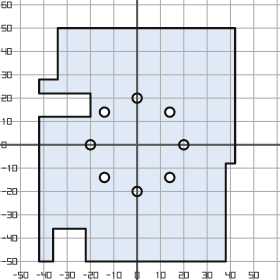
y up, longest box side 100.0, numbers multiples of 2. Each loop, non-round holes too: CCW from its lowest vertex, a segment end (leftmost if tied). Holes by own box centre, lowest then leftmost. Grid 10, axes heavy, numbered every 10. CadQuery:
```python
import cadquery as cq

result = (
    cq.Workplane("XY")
    .moveTo(-42.0, -50.0)
    .lineTo(-36.0, -50.0)
    .lineTo(-36.0, -36.0)
    .lineTo(-22.0, -36.0)
    .lineTo(-22.0, -50.0)
    .lineTo(38.0, -50.0)
    .lineTo(38.0, -8.0)
    .lineTo(42.0, -8.0)
    .lineTo(42.0, 50.0)
    .lineTo(-34.0, 50.0)
    .lineTo(-34.0, 28.0)
    .lineTo(-42.0, 28.0)
    .lineTo(-42.0, 22.0)
    .lineTo(-20.0, 22.0)
    .lineTo(-20.0, 12.0)
    .lineTo(-42.0, 12.0)
    .close()
    .moveTo(0.0, -20.0)
    .circle(2.0)
    .moveTo(-14.0, -14.0)
    .circle(2.0)
    .moveTo(14.0, -14.0)
    .circle(2.0)
    .moveTo(-20.0, 0.0)
    .circle(2.0)
    .moveTo(20.0, 0.0)
    .circle(2.0)
    .moveTo(-14.0, 14.0)
    .circle(2.0)
    .moveTo(14.0, 14.0)
    .circle(2.0)
    .moveTo(0.0, 20.0)
    .circle(2.0)
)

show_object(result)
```